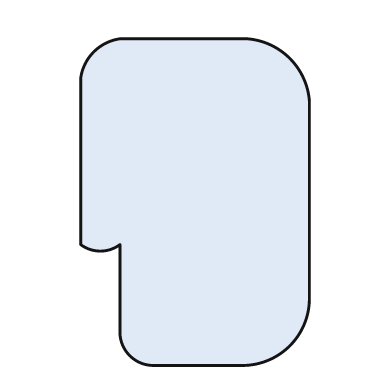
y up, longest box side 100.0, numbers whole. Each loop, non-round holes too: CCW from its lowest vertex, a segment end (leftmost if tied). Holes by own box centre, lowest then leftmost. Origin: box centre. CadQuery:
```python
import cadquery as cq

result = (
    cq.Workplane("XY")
    .moveTo(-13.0, -50.0)
    .lineTo(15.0, -50.0)
    .threePointArc((29.0, -44.0), (35.0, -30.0))
    .lineTo(35.0, 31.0)
    .threePointArc((29.0, 44.0), (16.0, 50.0))
    .lineTo(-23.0, 50.0)
    .threePointArc((-31.0, 46.0), (-35.0, 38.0))
    .lineTo(-35.0, -13.0)
    .threePointArc((-29.0, -15.0), (-23.0, -13.0))
    .lineTo(-23.0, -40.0)
    .threePointArc((-20.0, -47.0), (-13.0, -50.0))
    .close()
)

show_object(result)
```